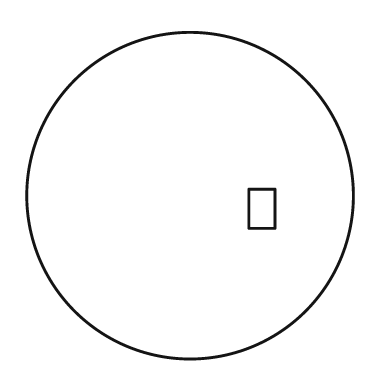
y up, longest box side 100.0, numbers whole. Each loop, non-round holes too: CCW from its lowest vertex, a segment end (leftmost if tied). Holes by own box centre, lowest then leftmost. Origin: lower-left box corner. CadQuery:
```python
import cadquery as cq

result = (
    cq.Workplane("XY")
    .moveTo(50.0, 50.0)
    .circle(50.0)
    .moveTo(68.0, 40.0)
    .lineTo(76.0, 40.0)
    .lineTo(76.0, 52.0)
    .lineTo(68.0, 52.0)
    .close()
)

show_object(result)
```